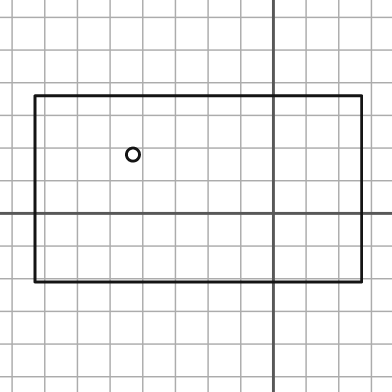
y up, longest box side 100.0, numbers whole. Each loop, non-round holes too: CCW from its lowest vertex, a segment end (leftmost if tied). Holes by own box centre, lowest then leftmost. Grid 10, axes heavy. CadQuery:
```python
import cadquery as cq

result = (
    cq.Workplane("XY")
    .moveTo(-73.0, -21.0)
    .lineTo(27.0, -21.0)
    .lineTo(27.0, 36.0)
    .lineTo(-73.0, 36.0)
    .close()
    .moveTo(-43.0, 18.0)
    .circle(2.0)
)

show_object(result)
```